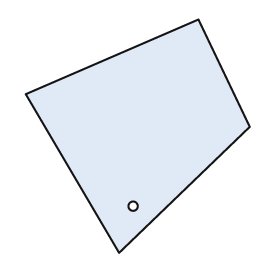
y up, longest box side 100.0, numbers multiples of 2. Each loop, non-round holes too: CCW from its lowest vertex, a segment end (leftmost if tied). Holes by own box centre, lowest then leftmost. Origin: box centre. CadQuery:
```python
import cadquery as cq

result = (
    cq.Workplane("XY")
    .moveTo(-8.0, -50.0)
    .lineTo(48.0, 4.0)
    .lineTo(26.0, 50.0)
    .lineTo(-48.0, 18.0)
    .close()
    .moveTo(-2.0, -30.0)
    .circle(2.0)
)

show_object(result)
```